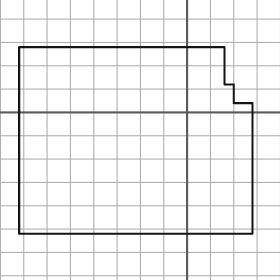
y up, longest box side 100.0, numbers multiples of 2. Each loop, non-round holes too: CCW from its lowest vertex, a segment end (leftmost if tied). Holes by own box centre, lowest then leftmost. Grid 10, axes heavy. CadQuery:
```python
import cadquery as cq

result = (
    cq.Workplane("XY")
    .moveTo(-72.0, -52.0)
    .lineTo(28.0, -52.0)
    .lineTo(28.0, 4.0)
    .lineTo(20.0, 4.0)
    .lineTo(20.0, 12.0)
    .lineTo(16.0, 12.0)
    .lineTo(16.0, 28.0)
    .lineTo(-72.0, 28.0)
    .close()
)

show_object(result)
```